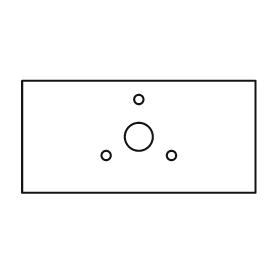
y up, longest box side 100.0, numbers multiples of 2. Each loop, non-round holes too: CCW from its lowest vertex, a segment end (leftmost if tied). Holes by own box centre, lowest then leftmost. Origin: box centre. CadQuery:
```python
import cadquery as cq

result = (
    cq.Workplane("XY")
    .moveTo(-50.0, -24.0)
    .lineTo(50.0, -24.0)
    .lineTo(50.0, 24.0)
    .lineTo(-50.0, 24.0)
    .close()
    .moveTo(-14.0, -8.0)
    .circle(2.0)
    .moveTo(14.0, -8.0)
    .circle(2.0)
    .moveTo(0.0, 0.0)
    .circle(6.0)
    .moveTo(0.0, 16.0)
    .circle(2.0)
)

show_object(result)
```